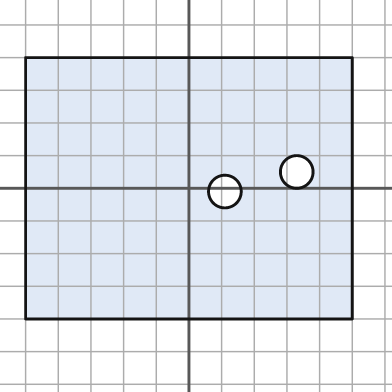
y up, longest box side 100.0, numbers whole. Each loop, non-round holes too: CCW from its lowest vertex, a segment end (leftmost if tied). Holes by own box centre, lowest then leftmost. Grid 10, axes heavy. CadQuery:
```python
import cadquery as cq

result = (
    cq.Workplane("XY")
    .moveTo(-50.0, -40.0)
    .lineTo(50.0, -40.0)
    .lineTo(50.0, 40.0)
    .lineTo(-50.0, 40.0)
    .close()
    .moveTo(11.0, -1.0)
    .circle(5.0)
    .moveTo(33.0, 5.0)
    .circle(5.0)
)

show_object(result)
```